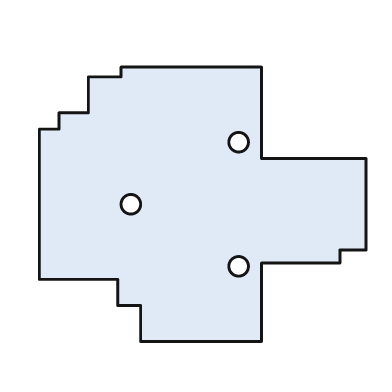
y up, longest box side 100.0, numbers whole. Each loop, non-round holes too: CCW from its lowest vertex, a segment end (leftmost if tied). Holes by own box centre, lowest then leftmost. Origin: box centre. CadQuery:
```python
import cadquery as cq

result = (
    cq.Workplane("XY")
    .moveTo(-19.0, -42.0)
    .lineTo(18.0, -42.0)
    .lineTo(18.0, -18.0)
    .lineTo(42.0, -18.0)
    .lineTo(42.0, -14.0)
    .lineTo(50.0, -14.0)
    .lineTo(50.0, 14.0)
    .lineTo(18.0, 14.0)
    .lineTo(18.0, 42.0)
    .lineTo(-25.0, 42.0)
    .lineTo(-25.0, 39.0)
    .lineTo(-35.0, 39.0)
    .lineTo(-35.0, 28.0)
    .lineTo(-44.0, 28.0)
    .lineTo(-44.0, 23.0)
    .lineTo(-50.0, 23.0)
    .lineTo(-50.0, -23.0)
    .lineTo(-26.0, -23.0)
    .lineTo(-26.0, -31.0)
    .lineTo(-19.0, -31.0)
    .close()
    .moveTo(11.0, -19.0)
    .circle(3.0)
    .moveTo(-22.0, 0.0)
    .circle(3.0)
    .moveTo(11.0, 19.0)
    .circle(3.0)
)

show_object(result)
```